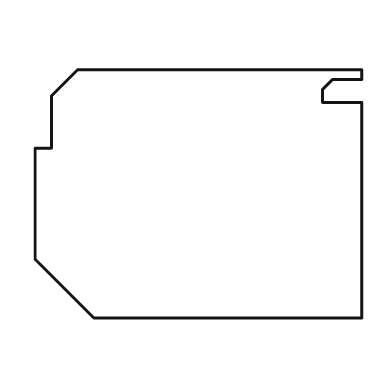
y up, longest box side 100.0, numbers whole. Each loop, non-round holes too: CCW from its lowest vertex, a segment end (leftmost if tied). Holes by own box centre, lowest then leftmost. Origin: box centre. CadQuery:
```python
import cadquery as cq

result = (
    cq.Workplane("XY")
    .moveTo(-32.0, -38.0)
    .lineTo(50.0, -38.0)
    .lineTo(50.0, 28.0)
    .lineTo(38.0, 28.0)
    .lineTo(38.0, 32.0)
    .lineTo(41.0, 35.0)
    .lineTo(50.0, 35.0)
    .lineTo(50.0, 38.0)
    .lineTo(-37.0, 38.0)
    .lineTo(-45.0, 30.0)
    .lineTo(-45.0, 14.0)
    .lineTo(-50.0, 14.0)
    .lineTo(-50.0, -20.0)
    .close()
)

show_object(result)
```